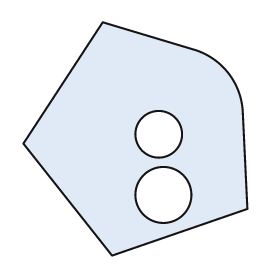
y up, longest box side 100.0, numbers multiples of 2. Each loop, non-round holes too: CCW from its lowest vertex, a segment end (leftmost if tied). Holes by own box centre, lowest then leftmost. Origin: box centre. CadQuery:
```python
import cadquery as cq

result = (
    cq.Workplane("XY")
    .moveTo(-10.0, -50.0)
    .lineTo(48.0, -30.0)
    .lineTo(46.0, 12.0)
    .threePointArc((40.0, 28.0), (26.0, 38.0))
    .lineTo(-14.0, 50.0)
    .lineTo(-48.0, -2.0)
    .close()
    .moveTo(12.0, -24.0)
    .circle(12.0)
    .moveTo(10.0, 2.0)
    .circle(10.0)
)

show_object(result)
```